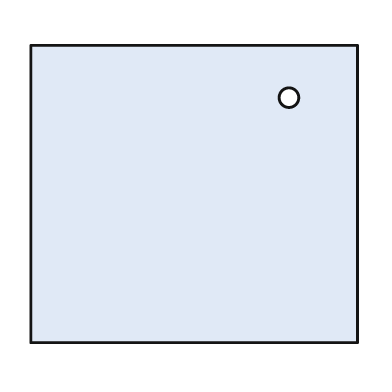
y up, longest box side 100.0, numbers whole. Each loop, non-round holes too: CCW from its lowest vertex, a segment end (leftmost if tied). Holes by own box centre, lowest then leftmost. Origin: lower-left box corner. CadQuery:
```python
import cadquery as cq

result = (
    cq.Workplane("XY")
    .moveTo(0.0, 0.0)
    .lineTo(100.0, 0.0)
    .lineTo(100.0, 91.0)
    .lineTo(0.0, 91.0)
    .close()
    .moveTo(79.0, 75.0)
    .circle(3.0)
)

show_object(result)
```